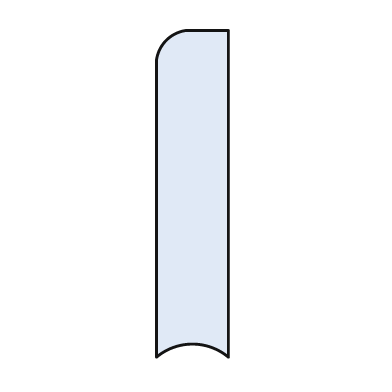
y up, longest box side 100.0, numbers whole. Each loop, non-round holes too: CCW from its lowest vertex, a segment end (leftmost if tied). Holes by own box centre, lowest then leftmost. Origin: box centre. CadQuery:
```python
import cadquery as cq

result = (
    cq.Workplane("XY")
    .moveTo(-11.0, -50.0)
    .threePointArc((0.0, -46.0), (11.0, -50.0))
    .lineTo(11.0, 50.0)
    .lineTo(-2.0, 50.0)
    .threePointArc((-8.0, 47.0), (-11.0, 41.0))
    .close()
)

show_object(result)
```